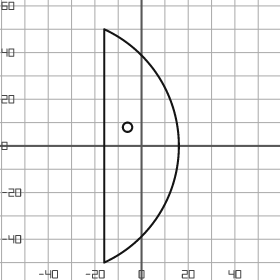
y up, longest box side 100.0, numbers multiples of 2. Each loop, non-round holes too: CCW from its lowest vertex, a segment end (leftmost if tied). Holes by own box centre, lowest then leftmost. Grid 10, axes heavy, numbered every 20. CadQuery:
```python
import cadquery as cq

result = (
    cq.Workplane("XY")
    .moveTo(-16.0, -50.0)
    .threePointArc((16.0, 0.0), (-16.0, 50.0))
    .close()
    .moveTo(-6.0, 8.0)
    .circle(2.0)
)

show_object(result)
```